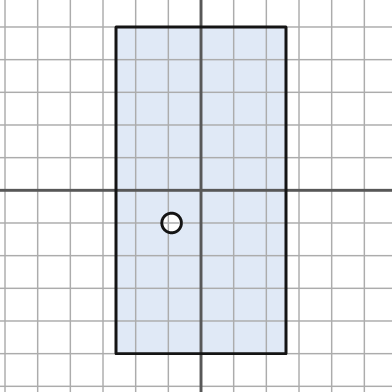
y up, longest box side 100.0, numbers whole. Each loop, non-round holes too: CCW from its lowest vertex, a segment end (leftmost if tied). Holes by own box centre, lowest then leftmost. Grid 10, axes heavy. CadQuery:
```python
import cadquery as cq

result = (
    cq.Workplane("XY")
    .moveTo(-26.0, -50.0)
    .lineTo(26.0, -50.0)
    .lineTo(26.0, 50.0)
    .lineTo(-26.0, 50.0)
    .close()
    .moveTo(-9.0, -10.0)
    .circle(3.0)
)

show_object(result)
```